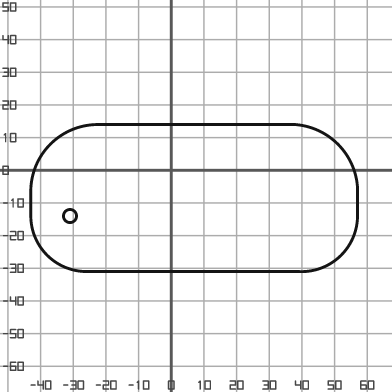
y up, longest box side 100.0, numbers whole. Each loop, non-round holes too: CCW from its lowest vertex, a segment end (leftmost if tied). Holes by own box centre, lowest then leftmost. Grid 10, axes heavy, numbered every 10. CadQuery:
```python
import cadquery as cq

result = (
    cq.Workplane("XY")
    .moveTo(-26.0, -31.0)
    .lineTo(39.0, -31.0)
    .threePointArc((52.0, -26.0), (57.0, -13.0))
    .lineTo(57.0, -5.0)
    .threePointArc((51.0, 8.0), (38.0, 14.0))
    .lineTo(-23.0, 14.0)
    .threePointArc((-37.0, 8.0), (-43.0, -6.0))
    .lineTo(-43.0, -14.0)
    .threePointArc((-38.0, -26.0), (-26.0, -31.0))
    .close()
    .moveTo(-31.0, -14.0)
    .circle(2.0)
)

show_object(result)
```